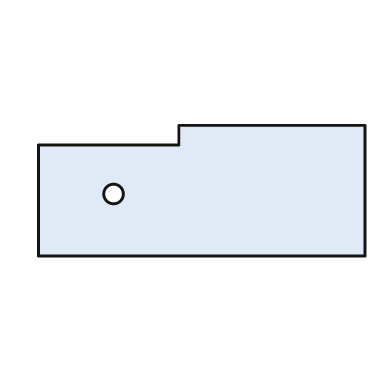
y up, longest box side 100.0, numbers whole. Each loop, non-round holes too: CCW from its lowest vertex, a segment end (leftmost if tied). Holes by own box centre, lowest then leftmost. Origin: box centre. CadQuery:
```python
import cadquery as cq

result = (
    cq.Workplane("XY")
    .moveTo(-50.0, -20.0)
    .lineTo(50.0, -20.0)
    .lineTo(50.0, 20.0)
    .lineTo(-7.0, 20.0)
    .lineTo(-7.0, 14.0)
    .lineTo(-50.0, 14.0)
    .close()
    .moveTo(-27.0, -1.0)
    .circle(3.0)
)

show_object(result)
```